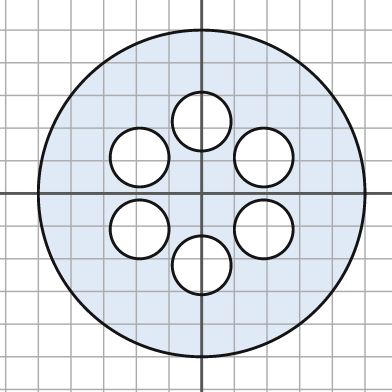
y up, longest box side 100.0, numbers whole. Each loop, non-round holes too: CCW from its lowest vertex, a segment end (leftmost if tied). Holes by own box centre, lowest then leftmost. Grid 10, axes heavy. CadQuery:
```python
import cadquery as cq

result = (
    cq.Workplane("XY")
    .moveTo(0.0, 0.0)
    .circle(50.0)
    .moveTo(0.0, -22.0)
    .circle(9.0)
    .moveTo(-19.0, -11.0)
    .circle(9.0)
    .moveTo(19.0, -11.0)
    .circle(9.0)
    .moveTo(-19.0, 11.0)
    .circle(9.0)
    .moveTo(19.0, 11.0)
    .circle(9.0)
    .moveTo(0.0, 22.0)
    .circle(9.0)
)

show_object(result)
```